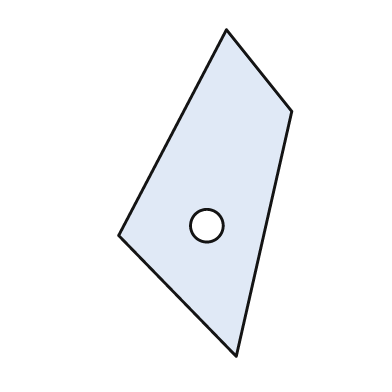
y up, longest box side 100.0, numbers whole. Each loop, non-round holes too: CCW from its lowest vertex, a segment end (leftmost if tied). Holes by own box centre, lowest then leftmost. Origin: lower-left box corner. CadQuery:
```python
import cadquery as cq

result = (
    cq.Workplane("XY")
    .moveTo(36.0, 0.0)
    .lineTo(53.0, 75.0)
    .lineTo(33.0, 100.0)
    .lineTo(0.0, 37.0)
    .close()
    .moveTo(27.0, 40.0)
    .circle(5.0)
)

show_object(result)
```